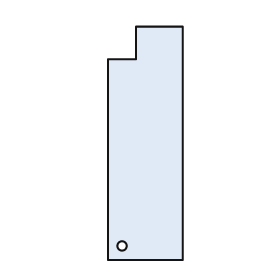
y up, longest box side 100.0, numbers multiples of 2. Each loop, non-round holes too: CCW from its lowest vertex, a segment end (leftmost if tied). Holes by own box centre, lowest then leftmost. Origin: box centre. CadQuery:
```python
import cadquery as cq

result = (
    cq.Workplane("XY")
    .moveTo(-16.0, -50.0)
    .lineTo(16.0, -50.0)
    .lineTo(16.0, 50.0)
    .lineTo(-4.0, 50.0)
    .lineTo(-4.0, 36.0)
    .lineTo(-16.0, 36.0)
    .close()
    .moveTo(-10.0, -44.0)
    .circle(2.0)
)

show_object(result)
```